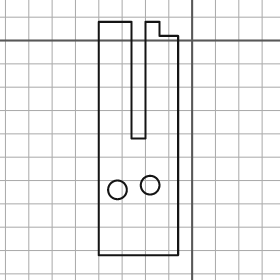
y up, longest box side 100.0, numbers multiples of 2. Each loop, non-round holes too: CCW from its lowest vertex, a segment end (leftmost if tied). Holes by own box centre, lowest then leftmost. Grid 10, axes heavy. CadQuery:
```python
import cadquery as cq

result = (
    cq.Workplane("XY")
    .moveTo(-40.0, -92.0)
    .lineTo(-6.0, -92.0)
    .lineTo(-6.0, 2.0)
    .lineTo(-14.0, 2.0)
    .lineTo(-14.0, 8.0)
    .lineTo(-20.0, 8.0)
    .lineTo(-20.0, -42.0)
    .lineTo(-26.0, -42.0)
    .lineTo(-26.0, 8.0)
    .lineTo(-40.0, 8.0)
    .close()
    .moveTo(-32.0, -64.0)
    .circle(4.0)
    .moveTo(-18.0, -62.0)
    .circle(4.0)
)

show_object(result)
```